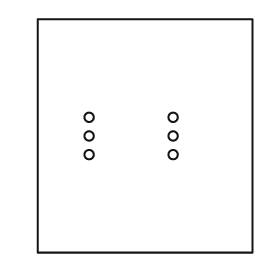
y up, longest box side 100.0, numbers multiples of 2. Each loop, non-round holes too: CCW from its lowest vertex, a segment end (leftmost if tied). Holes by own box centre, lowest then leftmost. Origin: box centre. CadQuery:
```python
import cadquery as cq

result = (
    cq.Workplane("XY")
    .moveTo(-46.0, -50.0)
    .lineTo(46.0, -50.0)
    .lineTo(46.0, 50.0)
    .lineTo(-46.0, 50.0)
    .close()
    .moveTo(-24.0, -8.0)
    .circle(2.0)
    .moveTo(12.0, -8.0)
    .circle(2.0)
    .moveTo(-24.0, 0.0)
    .circle(2.0)
    .moveTo(12.0, 0.0)
    .circle(2.0)
    .moveTo(-24.0, 8.0)
    .circle(2.0)
    .moveTo(12.0, 8.0)
    .circle(2.0)
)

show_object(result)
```